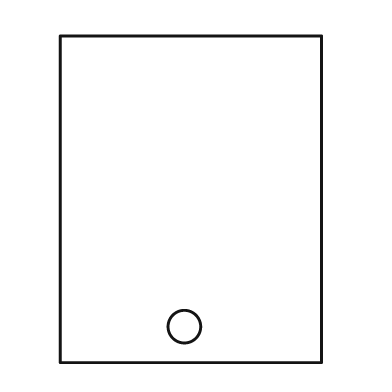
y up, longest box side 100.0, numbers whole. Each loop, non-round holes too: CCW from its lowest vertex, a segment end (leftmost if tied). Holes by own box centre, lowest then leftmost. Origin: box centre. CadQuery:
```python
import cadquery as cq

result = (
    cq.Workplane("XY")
    .moveTo(-40.0, -50.0)
    .lineTo(40.0, -50.0)
    .lineTo(40.0, 50.0)
    .lineTo(-40.0, 50.0)
    .close()
    .moveTo(-2.0, -39.0)
    .circle(5.0)
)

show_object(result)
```